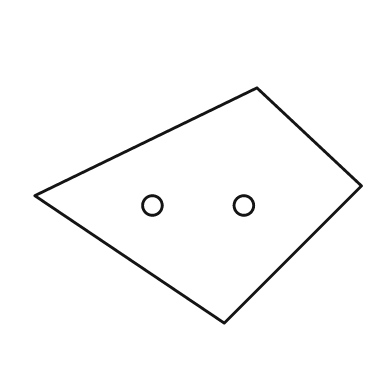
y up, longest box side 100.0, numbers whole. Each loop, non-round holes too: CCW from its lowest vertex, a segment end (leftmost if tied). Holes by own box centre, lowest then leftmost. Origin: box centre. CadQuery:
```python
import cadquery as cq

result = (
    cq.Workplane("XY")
    .moveTo(8.0, -36.0)
    .lineTo(50.0, 6.0)
    .lineTo(18.0, 36.0)
    .lineTo(-50.0, 3.0)
    .close()
    .moveTo(-14.0, 0.0)
    .circle(3.0)
    .moveTo(14.0, 0.0)
    .circle(3.0)
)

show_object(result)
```